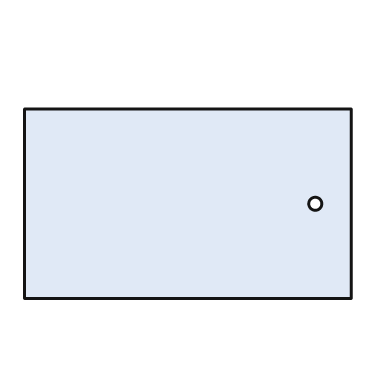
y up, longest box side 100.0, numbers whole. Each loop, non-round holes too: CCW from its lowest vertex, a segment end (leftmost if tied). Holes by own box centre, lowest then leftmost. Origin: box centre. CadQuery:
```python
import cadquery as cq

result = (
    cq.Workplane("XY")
    .moveTo(-50.0, -29.0)
    .lineTo(50.0, -29.0)
    .lineTo(50.0, 29.0)
    .lineTo(-50.0, 29.0)
    .close()
    .moveTo(39.0, 0.0)
    .circle(2.0)
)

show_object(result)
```